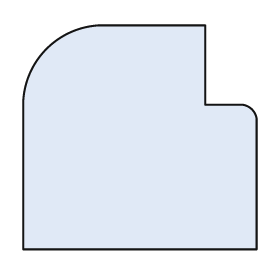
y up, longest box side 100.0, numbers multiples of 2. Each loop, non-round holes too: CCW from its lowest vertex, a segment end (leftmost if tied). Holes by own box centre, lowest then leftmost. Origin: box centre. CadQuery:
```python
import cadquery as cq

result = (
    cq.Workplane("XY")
    .moveTo(-50.0, -48.0)
    .lineTo(50.0, -48.0)
    .lineTo(50.0, 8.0)
    .threePointArc((48.0, 12.0), (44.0, 14.0))
    .lineTo(28.0, 14.0)
    .lineTo(28.0, 48.0)
    .lineTo(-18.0, 48.0)
    .threePointArc((-40.0, 38.0), (-50.0, 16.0))
    .close()
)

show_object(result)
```